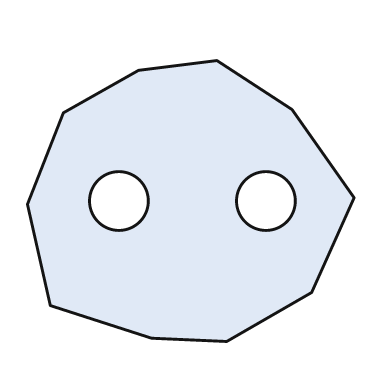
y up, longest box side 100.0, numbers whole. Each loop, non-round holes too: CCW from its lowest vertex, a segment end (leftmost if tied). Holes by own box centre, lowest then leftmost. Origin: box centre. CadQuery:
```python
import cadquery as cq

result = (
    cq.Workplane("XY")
    .moveTo(11.0, -43.0)
    .lineTo(37.0, -28.0)
    .lineTo(50.0, 1.0)
    .lineTo(31.0, 28.0)
    .lineTo(8.0, 43.0)
    .lineTo(-16.0, 40.0)
    .lineTo(-39.0, 27.0)
    .lineTo(-50.0, -1.0)
    .lineTo(-43.0, -32.0)
    .lineTo(-12.0, -42.0)
    .close()
    .moveTo(-22.0, 0.0)
    .circle(9.0)
    .moveTo(23.0, 0.0)
    .circle(9.0)
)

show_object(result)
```